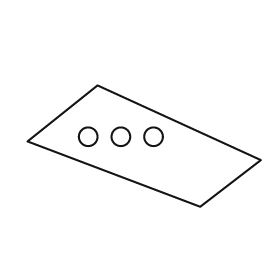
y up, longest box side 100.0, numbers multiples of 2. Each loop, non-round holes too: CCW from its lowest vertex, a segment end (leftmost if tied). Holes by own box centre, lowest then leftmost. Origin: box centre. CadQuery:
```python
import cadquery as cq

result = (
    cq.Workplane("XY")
    .moveTo(24.0, -26.0)
    .lineTo(50.0, -6.0)
    .lineTo(-20.0, 26.0)
    .lineTo(-50.0, 2.0)
    .close()
    .moveTo(-24.0, 4.0)
    .circle(4.0)
    .moveTo(-10.0, 4.0)
    .circle(4.0)
    .moveTo(4.0, 4.0)
    .circle(4.0)
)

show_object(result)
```